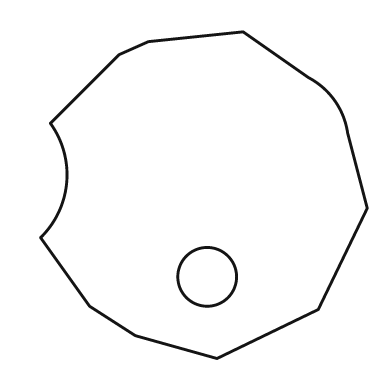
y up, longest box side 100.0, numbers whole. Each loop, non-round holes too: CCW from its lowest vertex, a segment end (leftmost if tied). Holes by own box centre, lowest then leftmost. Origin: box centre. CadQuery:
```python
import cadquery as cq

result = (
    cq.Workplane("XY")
    .moveTo(4.0, -50.0)
    .lineTo(35.0, -35.0)
    .lineTo(50.0, -4.0)
    .lineTo(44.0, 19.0)
    .threePointArc((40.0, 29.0), (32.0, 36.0))
    .lineTo(12.0, 50.0)
    .lineTo(-17.0, 47.0)
    .lineTo(-26.0, 43.0)
    .lineTo(-47.0, 22.0)
    .threePointArc((-42.0, 4.0), (-50.0, -13.0))
    .lineTo(-35.0, -34.0)
    .lineTo(-21.0, -43.0)
    .close()
    .moveTo(1.0, -25.0)
    .circle(9.0)
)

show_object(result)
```